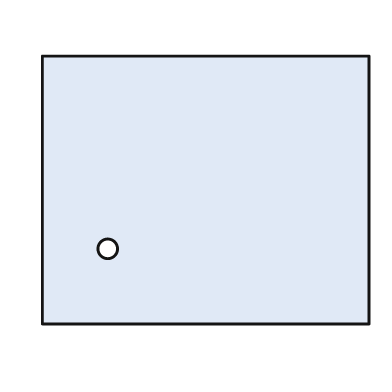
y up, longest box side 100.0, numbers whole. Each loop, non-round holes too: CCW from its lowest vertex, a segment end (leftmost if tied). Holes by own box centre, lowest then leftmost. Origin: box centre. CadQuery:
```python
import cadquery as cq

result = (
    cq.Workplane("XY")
    .moveTo(-50.0, -41.0)
    .lineTo(50.0, -41.0)
    .lineTo(50.0, 41.0)
    .lineTo(-50.0, 41.0)
    .close()
    .moveTo(-30.0, -18.0)
    .circle(3.0)
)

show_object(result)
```